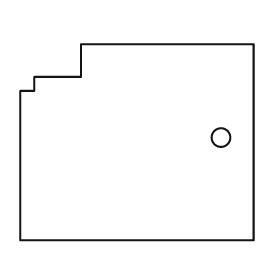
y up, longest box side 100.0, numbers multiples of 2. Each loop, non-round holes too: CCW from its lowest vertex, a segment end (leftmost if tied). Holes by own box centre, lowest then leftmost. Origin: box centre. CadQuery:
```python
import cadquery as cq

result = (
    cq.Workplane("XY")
    .moveTo(-50.0, -42.0)
    .lineTo(50.0, -42.0)
    .lineTo(50.0, 42.0)
    .lineTo(-24.0, 42.0)
    .lineTo(-24.0, 28.0)
    .lineTo(-44.0, 28.0)
    .lineTo(-44.0, 22.0)
    .lineTo(-50.0, 22.0)
    .close()
    .moveTo(36.0, 2.0)
    .circle(4.0)
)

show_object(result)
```